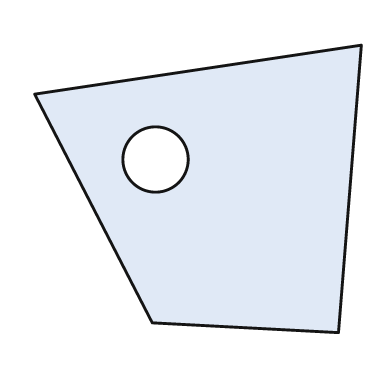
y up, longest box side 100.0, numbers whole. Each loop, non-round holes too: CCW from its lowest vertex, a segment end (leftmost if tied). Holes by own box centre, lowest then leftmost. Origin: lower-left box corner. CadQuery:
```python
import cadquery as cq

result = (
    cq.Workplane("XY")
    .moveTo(93.0, 0.0)
    .lineTo(100.0, 88.0)
    .lineTo(0.0, 73.0)
    .lineTo(36.0, 3.0)
    .close()
    .moveTo(37.0, 53.0)
    .circle(10.0)
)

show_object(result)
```